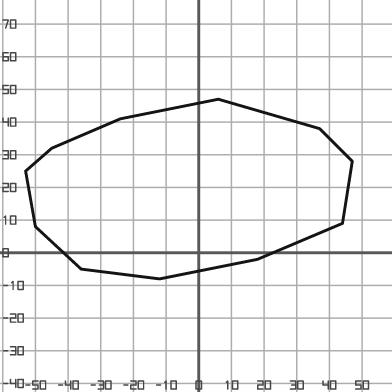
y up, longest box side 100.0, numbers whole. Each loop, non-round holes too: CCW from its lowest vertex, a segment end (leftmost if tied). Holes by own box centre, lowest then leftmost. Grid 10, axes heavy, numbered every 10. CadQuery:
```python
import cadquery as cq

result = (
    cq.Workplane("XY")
    .moveTo(-12.0, -8.0)
    .lineTo(18.0, -2.0)
    .lineTo(44.0, 9.0)
    .lineTo(47.0, 28.0)
    .lineTo(37.0, 38.0)
    .lineTo(6.0, 47.0)
    .lineTo(-24.0, 41.0)
    .lineTo(-45.0, 32.0)
    .lineTo(-53.0, 25.0)
    .lineTo(-50.0, 8.0)
    .lineTo(-36.0, -5.0)
    .close()
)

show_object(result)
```